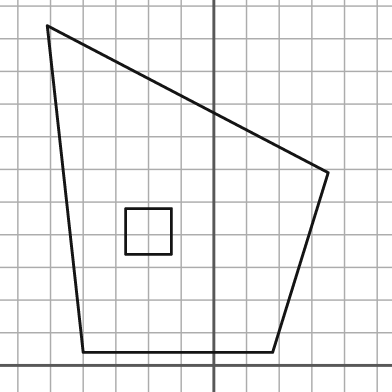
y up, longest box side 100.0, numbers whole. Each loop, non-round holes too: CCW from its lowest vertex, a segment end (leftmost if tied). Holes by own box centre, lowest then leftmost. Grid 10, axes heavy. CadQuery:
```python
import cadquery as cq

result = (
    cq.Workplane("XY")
    .moveTo(-40.0, 4.0)
    .lineTo(18.0, 4.0)
    .lineTo(35.0, 59.0)
    .lineTo(-51.0, 104.0)
    .close()
    .moveTo(-27.0, 34.0)
    .lineTo(-13.0, 34.0)
    .lineTo(-13.0, 48.0)
    .lineTo(-27.0, 48.0)
    .close()
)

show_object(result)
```